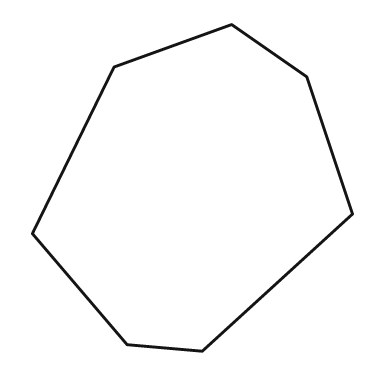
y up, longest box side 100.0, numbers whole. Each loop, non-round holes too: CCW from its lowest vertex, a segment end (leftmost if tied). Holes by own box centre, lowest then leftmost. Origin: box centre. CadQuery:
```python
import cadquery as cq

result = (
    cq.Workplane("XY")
    .moveTo(3.0, -50.0)
    .lineTo(49.0, -8.0)
    .lineTo(35.0, 34.0)
    .lineTo(12.0, 50.0)
    .lineTo(-24.0, 37.0)
    .lineTo(-49.0, -14.0)
    .lineTo(-20.0, -48.0)
    .close()
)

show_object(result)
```